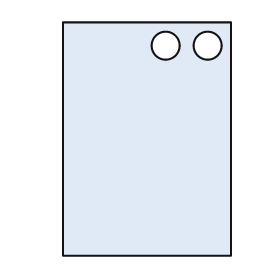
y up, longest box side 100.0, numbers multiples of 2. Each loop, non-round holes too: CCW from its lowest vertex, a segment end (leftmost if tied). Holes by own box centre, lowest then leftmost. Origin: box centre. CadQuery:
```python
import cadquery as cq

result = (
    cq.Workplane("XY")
    .moveTo(-36.0, -50.0)
    .lineTo(36.0, -50.0)
    .lineTo(36.0, 50.0)
    .lineTo(-36.0, 50.0)
    .close()
    .moveTo(8.0, 40.0)
    .circle(6.0)
    .moveTo(26.0, 40.0)
    .circle(6.0)
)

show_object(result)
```